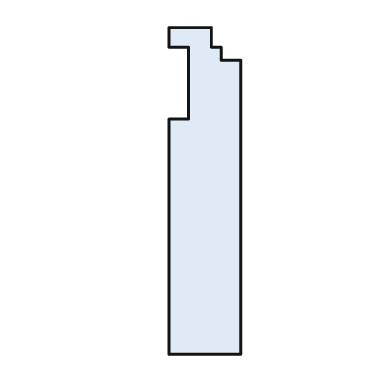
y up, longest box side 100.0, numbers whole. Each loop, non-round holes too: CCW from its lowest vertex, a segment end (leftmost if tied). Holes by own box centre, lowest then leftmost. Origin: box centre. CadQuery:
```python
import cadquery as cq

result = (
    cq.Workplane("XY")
    .moveTo(-11.0, -50.0)
    .lineTo(11.0, -50.0)
    .lineTo(11.0, 40.0)
    .lineTo(5.0, 40.0)
    .lineTo(5.0, 44.0)
    .lineTo(2.0, 44.0)
    .lineTo(2.0, 50.0)
    .lineTo(-11.0, 50.0)
    .lineTo(-11.0, 44.0)
    .lineTo(-5.0, 44.0)
    .lineTo(-5.0, 22.0)
    .lineTo(-11.0, 22.0)
    .close()
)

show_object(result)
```